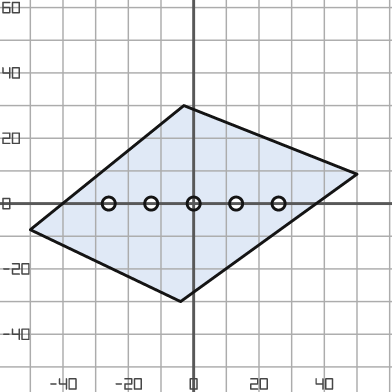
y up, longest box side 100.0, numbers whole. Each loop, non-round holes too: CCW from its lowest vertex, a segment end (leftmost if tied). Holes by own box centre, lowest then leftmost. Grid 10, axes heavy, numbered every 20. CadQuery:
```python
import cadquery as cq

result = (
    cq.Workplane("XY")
    .moveTo(-4.0, -30.0)
    .lineTo(50.0, 9.0)
    .lineTo(-3.0, 30.0)
    .lineTo(-50.0, -8.0)
    .close()
    .moveTo(-26.0, 0.0)
    .circle(2.0)
    .moveTo(-13.0, 0.0)
    .circle(2.0)
    .moveTo(0.0, 0.0)
    .circle(2.0)
    .moveTo(13.0, 0.0)
    .circle(2.0)
    .moveTo(26.0, 0.0)
    .circle(2.0)
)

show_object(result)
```